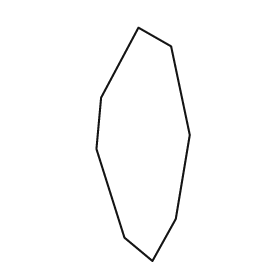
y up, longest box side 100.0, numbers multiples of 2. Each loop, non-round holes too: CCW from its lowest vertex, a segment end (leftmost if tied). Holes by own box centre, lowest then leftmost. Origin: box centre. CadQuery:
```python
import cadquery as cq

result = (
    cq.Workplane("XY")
    .moveTo(4.0, -50.0)
    .lineTo(14.0, -32.0)
    .lineTo(20.0, 4.0)
    .lineTo(12.0, 42.0)
    .lineTo(-2.0, 50.0)
    .lineTo(-18.0, 20.0)
    .lineTo(-20.0, -2.0)
    .lineTo(-8.0, -40.0)
    .close()
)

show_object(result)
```